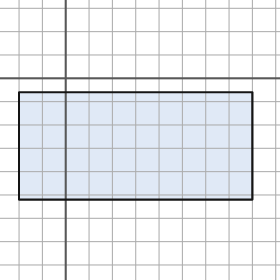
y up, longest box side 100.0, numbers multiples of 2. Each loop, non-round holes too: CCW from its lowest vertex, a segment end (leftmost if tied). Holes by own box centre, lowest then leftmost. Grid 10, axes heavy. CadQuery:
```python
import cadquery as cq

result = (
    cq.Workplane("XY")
    .moveTo(-20.0, -52.0)
    .lineTo(80.0, -52.0)
    .lineTo(80.0, -6.0)
    .lineTo(-20.0, -6.0)
    .close()
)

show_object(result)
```